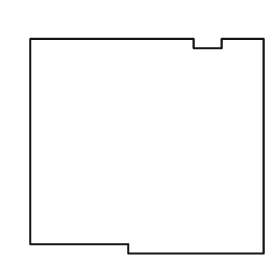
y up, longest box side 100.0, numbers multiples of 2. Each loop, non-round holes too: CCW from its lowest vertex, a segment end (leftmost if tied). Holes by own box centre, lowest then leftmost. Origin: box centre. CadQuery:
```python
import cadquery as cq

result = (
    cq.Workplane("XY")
    .moveTo(-8.0, -46.0)
    .lineTo(50.0, -46.0)
    .lineTo(50.0, 46.0)
    .lineTo(32.0, 46.0)
    .lineTo(32.0, 42.0)
    .lineTo(20.0, 42.0)
    .lineTo(20.0, 46.0)
    .lineTo(-50.0, 46.0)
    .lineTo(-50.0, -42.0)
    .lineTo(-8.0, -42.0)
    .close()
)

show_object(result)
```